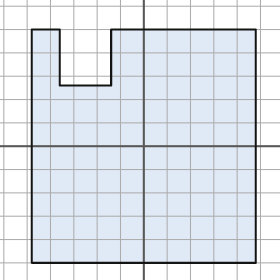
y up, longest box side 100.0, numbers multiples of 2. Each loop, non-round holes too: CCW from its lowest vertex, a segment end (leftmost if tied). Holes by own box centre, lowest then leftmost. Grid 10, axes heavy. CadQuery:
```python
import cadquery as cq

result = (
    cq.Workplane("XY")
    .moveTo(-48.0, -50.0)
    .lineTo(48.0, -50.0)
    .lineTo(48.0, 50.0)
    .lineTo(-14.0, 50.0)
    .lineTo(-14.0, 26.0)
    .lineTo(-36.0, 26.0)
    .lineTo(-36.0, 50.0)
    .lineTo(-48.0, 50.0)
    .close()
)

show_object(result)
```